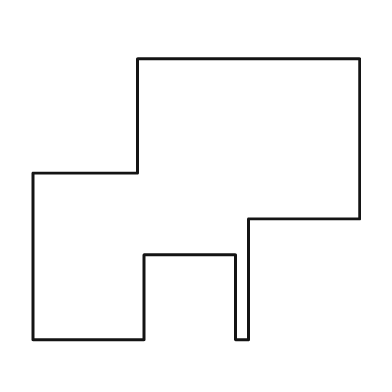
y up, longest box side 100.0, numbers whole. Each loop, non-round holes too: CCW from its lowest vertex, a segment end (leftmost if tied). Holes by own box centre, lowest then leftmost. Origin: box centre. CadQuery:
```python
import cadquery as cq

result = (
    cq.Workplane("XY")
    .moveTo(-50.0, -43.0)
    .lineTo(-16.0, -43.0)
    .lineTo(-16.0, -17.0)
    .lineTo(12.0, -17.0)
    .lineTo(12.0, -43.0)
    .lineTo(16.0, -43.0)
    .lineTo(16.0, -6.0)
    .lineTo(50.0, -6.0)
    .lineTo(50.0, 43.0)
    .lineTo(-18.0, 43.0)
    .lineTo(-18.0, 8.0)
    .lineTo(-50.0, 8.0)
    .close()
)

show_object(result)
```